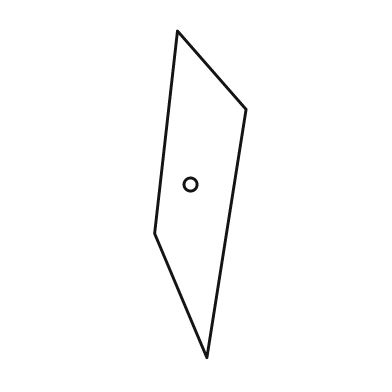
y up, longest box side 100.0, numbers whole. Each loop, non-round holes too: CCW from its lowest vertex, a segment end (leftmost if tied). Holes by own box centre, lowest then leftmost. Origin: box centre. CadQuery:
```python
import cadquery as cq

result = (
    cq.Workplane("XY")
    .moveTo(2.0, -50.0)
    .lineTo(14.0, 26.0)
    .lineTo(-7.0, 50.0)
    .lineTo(-14.0, -12.0)
    .close()
    .moveTo(-3.0, 3.0)
    .circle(2.0)
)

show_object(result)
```